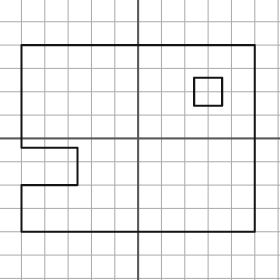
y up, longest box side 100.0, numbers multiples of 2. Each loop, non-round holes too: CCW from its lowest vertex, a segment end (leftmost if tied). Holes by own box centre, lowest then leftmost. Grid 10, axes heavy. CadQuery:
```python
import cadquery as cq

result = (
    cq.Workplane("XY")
    .moveTo(-50.0, -40.0)
    .lineTo(50.0, -40.0)
    .lineTo(50.0, 40.0)
    .lineTo(-50.0, 40.0)
    .lineTo(-50.0, -4.0)
    .lineTo(-26.0, -4.0)
    .lineTo(-26.0, -20.0)
    .lineTo(-50.0, -20.0)
    .close()
    .moveTo(24.0, 14.0)
    .lineTo(36.0, 14.0)
    .lineTo(36.0, 26.0)
    .lineTo(24.0, 26.0)
    .close()
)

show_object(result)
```